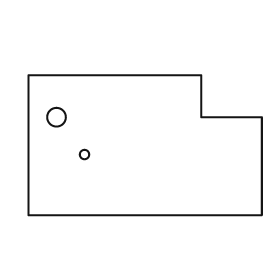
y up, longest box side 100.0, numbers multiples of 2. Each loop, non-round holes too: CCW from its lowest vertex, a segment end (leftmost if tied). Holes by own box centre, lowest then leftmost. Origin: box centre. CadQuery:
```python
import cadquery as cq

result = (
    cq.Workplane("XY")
    .moveTo(-50.0, -30.0)
    .lineTo(50.0, -30.0)
    .lineTo(50.0, 12.0)
    .lineTo(24.0, 12.0)
    .lineTo(24.0, 30.0)
    .lineTo(-50.0, 30.0)
    .close()
    .moveTo(-26.0, -4.0)
    .circle(2.0)
    .moveTo(-38.0, 12.0)
    .circle(4.0)
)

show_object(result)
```